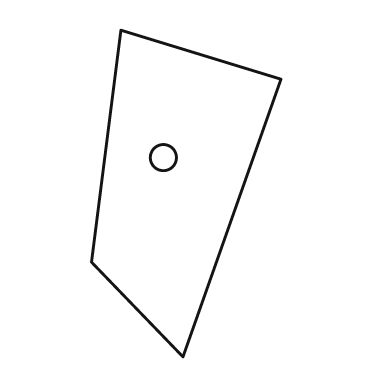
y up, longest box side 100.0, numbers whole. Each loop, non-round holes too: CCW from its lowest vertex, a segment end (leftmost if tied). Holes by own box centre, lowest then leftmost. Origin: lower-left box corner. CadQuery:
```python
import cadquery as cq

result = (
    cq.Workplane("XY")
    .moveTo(28.0, 0.0)
    .lineTo(58.0, 85.0)
    .lineTo(9.0, 100.0)
    .lineTo(0.0, 29.0)
    .close()
    .moveTo(22.0, 61.0)
    .circle(4.0)
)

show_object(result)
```